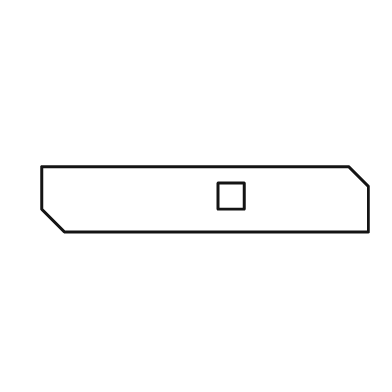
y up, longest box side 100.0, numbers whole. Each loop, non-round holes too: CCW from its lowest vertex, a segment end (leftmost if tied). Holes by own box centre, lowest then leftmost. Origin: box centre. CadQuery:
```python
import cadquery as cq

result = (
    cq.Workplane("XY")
    .moveTo(-43.0, -10.0)
    .lineTo(50.0, -10.0)
    .lineTo(50.0, 4.0)
    .lineTo(44.0, 10.0)
    .lineTo(-50.0, 10.0)
    .lineTo(-50.0, -3.0)
    .close()
    .moveTo(4.0, -3.0)
    .lineTo(12.0, -3.0)
    .lineTo(12.0, 5.0)
    .lineTo(4.0, 5.0)
    .close()
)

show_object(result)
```